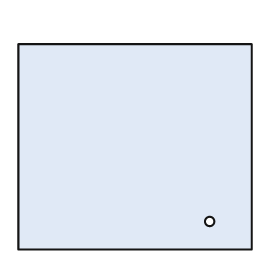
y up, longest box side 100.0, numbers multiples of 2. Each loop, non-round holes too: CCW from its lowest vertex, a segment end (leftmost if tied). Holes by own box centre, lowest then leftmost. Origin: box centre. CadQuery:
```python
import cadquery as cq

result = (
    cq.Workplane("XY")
    .moveTo(-50.0, -44.0)
    .lineTo(50.0, -44.0)
    .lineTo(50.0, 44.0)
    .lineTo(-50.0, 44.0)
    .close()
    .moveTo(32.0, -32.0)
    .circle(2.0)
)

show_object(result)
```